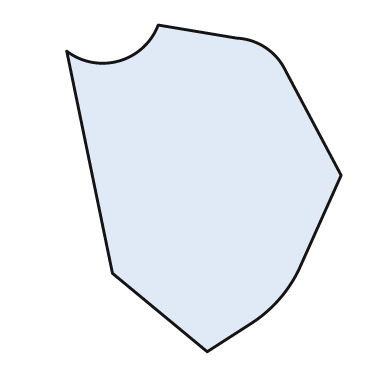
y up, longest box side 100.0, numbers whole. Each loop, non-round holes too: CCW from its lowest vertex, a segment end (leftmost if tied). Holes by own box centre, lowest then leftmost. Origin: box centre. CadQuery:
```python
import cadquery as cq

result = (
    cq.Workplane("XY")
    .moveTo(1.0, -50.0)
    .lineTo(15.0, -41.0)
    .threePointArc((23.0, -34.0), (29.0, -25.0))
    .lineTo(42.0, 4.0)
    .lineTo(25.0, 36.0)
    .threePointArc((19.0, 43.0), (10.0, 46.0))
    .lineTo(-14.0, 50.0)
    .threePointArc((-26.0, 39.0), (-42.0, 42.0))
    .lineTo(-28.0, -26.0)
    .close()
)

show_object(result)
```